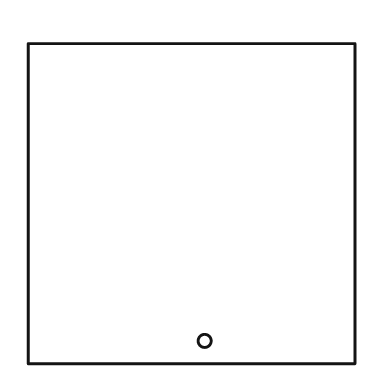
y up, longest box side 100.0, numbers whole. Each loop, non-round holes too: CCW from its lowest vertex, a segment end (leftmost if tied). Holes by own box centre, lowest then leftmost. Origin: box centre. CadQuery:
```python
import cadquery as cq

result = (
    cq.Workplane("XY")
    .moveTo(-50.0, -49.0)
    .lineTo(50.0, -49.0)
    .lineTo(50.0, 49.0)
    .lineTo(-50.0, 49.0)
    .close()
    .moveTo(4.0, -42.0)
    .circle(2.0)
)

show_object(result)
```